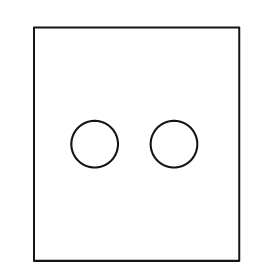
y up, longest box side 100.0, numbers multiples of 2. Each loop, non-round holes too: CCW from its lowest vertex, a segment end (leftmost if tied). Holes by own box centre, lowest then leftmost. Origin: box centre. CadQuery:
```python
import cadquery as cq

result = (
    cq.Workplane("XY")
    .moveTo(-44.0, -50.0)
    .lineTo(44.0, -50.0)
    .lineTo(44.0, 50.0)
    .lineTo(-44.0, 50.0)
    .close()
    .moveTo(-18.0, 0.0)
    .circle(10.0)
    .moveTo(16.0, 0.0)
    .circle(10.0)
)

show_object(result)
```